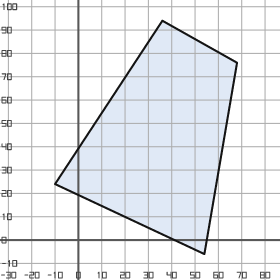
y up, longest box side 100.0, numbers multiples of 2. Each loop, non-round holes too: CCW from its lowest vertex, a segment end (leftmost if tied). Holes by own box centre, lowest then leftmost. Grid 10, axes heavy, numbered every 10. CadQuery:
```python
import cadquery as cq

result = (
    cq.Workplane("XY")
    .moveTo(54.0, -6.0)
    .lineTo(68.0, 76.0)
    .lineTo(36.0, 94.0)
    .lineTo(-10.0, 24.0)
    .close()
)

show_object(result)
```